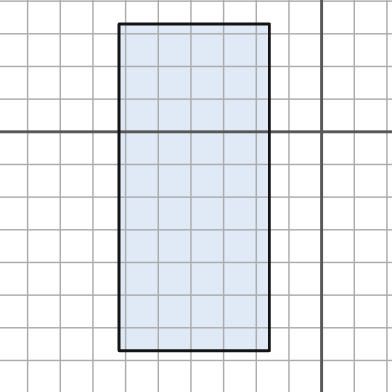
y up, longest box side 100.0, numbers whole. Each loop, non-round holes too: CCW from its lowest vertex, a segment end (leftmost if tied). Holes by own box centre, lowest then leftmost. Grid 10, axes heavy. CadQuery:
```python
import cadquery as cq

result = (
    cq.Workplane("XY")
    .moveTo(-62.0, -67.0)
    .lineTo(-16.0, -67.0)
    .lineTo(-16.0, 33.0)
    .lineTo(-62.0, 33.0)
    .close()
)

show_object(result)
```